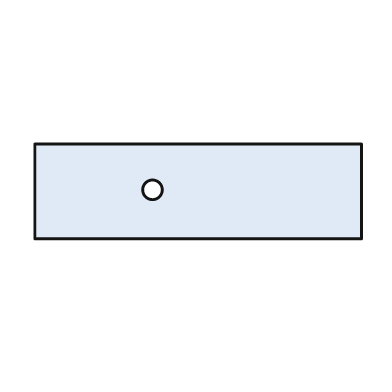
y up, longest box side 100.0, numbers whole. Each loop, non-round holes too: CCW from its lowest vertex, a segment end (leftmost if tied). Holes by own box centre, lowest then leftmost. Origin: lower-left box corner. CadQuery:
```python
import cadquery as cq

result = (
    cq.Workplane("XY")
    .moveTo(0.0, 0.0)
    .lineTo(100.0, 0.0)
    .lineTo(100.0, 29.0)
    .lineTo(0.0, 29.0)
    .close()
    .moveTo(36.0, 15.0)
    .circle(3.0)
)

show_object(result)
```